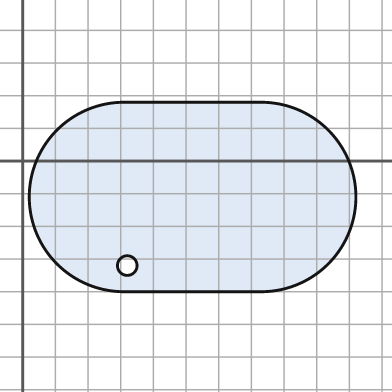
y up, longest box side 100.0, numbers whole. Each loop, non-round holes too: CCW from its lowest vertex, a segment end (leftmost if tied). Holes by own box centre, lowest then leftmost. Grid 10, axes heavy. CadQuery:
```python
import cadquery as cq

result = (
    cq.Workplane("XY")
    .moveTo(31.0, -40.0)
    .lineTo(73.0, -40.0)
    .threePointArc((102.0, -11.0), (73.0, 18.0))
    .lineTo(31.0, 18.0)
    .threePointArc((2.0, -11.0), (31.0, -40.0))
    .close()
    .moveTo(32.0, -32.0)
    .circle(3.0)
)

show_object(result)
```